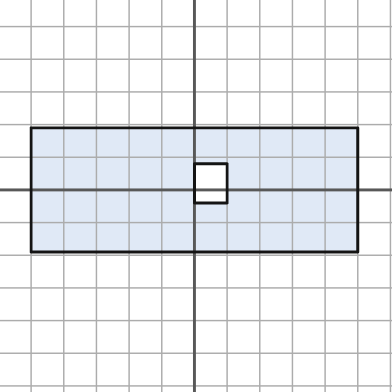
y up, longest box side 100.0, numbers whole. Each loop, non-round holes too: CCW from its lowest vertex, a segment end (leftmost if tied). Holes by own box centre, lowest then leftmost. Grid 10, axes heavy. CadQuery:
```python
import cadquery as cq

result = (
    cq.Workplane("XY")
    .moveTo(-50.0, -19.0)
    .lineTo(50.0, -19.0)
    .lineTo(50.0, 19.0)
    .lineTo(-50.0, 19.0)
    .close()
    .moveTo(0.0, -4.0)
    .lineTo(10.0, -4.0)
    .lineTo(10.0, 8.0)
    .lineTo(0.0, 8.0)
    .close()
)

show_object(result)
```